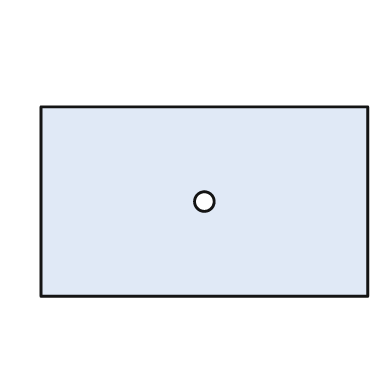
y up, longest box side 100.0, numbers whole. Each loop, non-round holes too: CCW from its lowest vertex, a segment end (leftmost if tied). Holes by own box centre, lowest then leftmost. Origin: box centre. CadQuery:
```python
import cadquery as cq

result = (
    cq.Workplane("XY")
    .moveTo(-50.0, -29.0)
    .lineTo(50.0, -29.0)
    .lineTo(50.0, 29.0)
    .lineTo(-50.0, 29.0)
    .close()
    .moveTo(0.0, 0.0)
    .circle(3.0)
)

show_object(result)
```